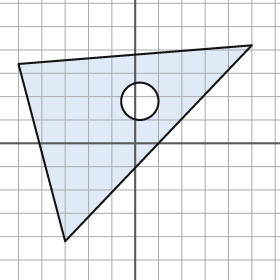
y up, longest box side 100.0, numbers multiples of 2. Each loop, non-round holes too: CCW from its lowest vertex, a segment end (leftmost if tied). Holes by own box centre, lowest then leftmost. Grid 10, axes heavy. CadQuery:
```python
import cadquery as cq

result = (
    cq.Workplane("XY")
    .moveTo(-30.0, -42.0)
    .lineTo(50.0, 42.0)
    .lineTo(-50.0, 34.0)
    .close()
    .moveTo(2.0, 18.0)
    .circle(8.0)
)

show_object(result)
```